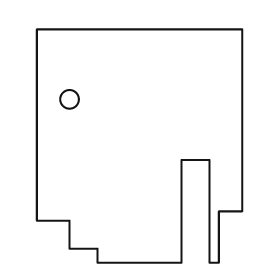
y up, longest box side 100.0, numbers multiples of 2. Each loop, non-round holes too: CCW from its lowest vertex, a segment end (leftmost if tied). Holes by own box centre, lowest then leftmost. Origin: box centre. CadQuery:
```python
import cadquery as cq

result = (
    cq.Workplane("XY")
    .moveTo(-18.0, -50.0)
    .lineTo(18.0, -50.0)
    .lineTo(18.0, -6.0)
    .lineTo(30.0, -6.0)
    .lineTo(30.0, -50.0)
    .lineTo(34.0, -50.0)
    .lineTo(34.0, -28.0)
    .lineTo(44.0, -28.0)
    .lineTo(44.0, 50.0)
    .lineTo(-44.0, 50.0)
    .lineTo(-44.0, -32.0)
    .lineTo(-30.0, -32.0)
    .lineTo(-30.0, -44.0)
    .lineTo(-18.0, -44.0)
    .close()
    .moveTo(-30.0, 20.0)
    .circle(4.0)
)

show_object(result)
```